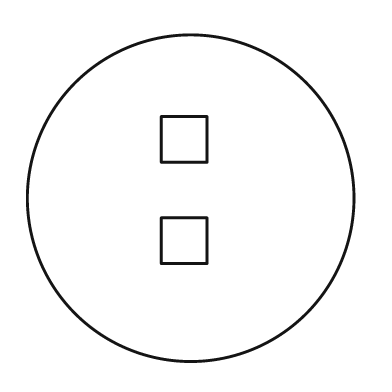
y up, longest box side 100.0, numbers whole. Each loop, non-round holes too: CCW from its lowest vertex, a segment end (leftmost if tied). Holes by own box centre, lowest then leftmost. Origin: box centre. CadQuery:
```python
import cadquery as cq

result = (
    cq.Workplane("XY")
    .moveTo(0.0, 0.0)
    .circle(50.0)
    .moveTo(-9.0, -20.0)
    .lineTo(5.0, -20.0)
    .lineTo(5.0, -6.0)
    .lineTo(-9.0, -6.0)
    .close()
    .moveTo(-9.0, 11.0)
    .lineTo(5.0, 11.0)
    .lineTo(5.0, 25.0)
    .lineTo(-9.0, 25.0)
    .close()
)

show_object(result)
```